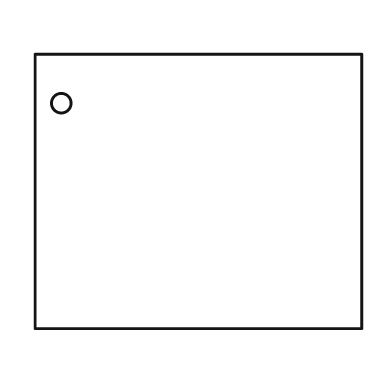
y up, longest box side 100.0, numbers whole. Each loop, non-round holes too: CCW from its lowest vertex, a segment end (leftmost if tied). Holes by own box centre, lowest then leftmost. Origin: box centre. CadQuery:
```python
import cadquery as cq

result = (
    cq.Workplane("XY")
    .moveTo(-50.0, -42.0)
    .lineTo(50.0, -42.0)
    .lineTo(50.0, 42.0)
    .lineTo(-50.0, 42.0)
    .close()
    .moveTo(-42.0, 27.0)
    .circle(3.0)
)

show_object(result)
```